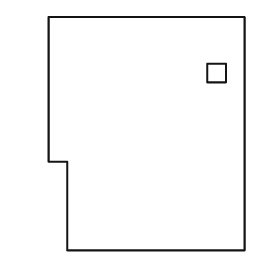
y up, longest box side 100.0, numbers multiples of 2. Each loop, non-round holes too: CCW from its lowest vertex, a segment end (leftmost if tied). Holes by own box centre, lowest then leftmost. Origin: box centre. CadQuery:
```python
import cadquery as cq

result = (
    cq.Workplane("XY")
    .moveTo(-34.0, -50.0)
    .lineTo(42.0, -50.0)
    .lineTo(42.0, 50.0)
    .lineTo(-42.0, 50.0)
    .lineTo(-42.0, -12.0)
    .lineTo(-34.0, -12.0)
    .close()
    .moveTo(26.0, 22.0)
    .lineTo(34.0, 22.0)
    .lineTo(34.0, 30.0)
    .lineTo(26.0, 30.0)
    .close()
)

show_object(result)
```